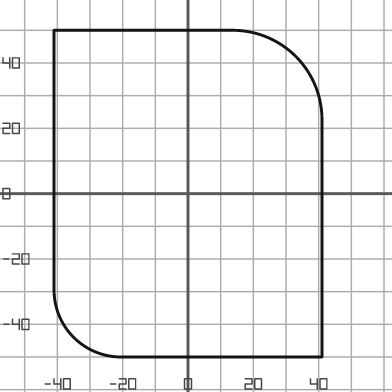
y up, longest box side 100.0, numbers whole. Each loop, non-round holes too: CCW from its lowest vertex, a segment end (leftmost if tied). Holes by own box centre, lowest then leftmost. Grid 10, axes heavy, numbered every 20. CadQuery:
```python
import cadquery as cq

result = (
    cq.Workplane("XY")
    .moveTo(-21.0, -50.0)
    .lineTo(41.0, -50.0)
    .lineTo(41.0, 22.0)
    .threePointArc((33.0, 42.0), (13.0, 50.0))
    .lineTo(-41.0, 50.0)
    .lineTo(-41.0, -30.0)
    .threePointArc((-35.0, -44.0), (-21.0, -50.0))
    .close()
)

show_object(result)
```